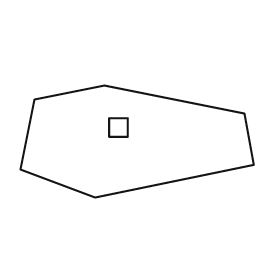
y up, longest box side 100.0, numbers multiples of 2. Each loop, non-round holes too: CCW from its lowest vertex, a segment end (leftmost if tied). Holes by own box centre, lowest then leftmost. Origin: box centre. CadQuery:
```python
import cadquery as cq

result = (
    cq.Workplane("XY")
    .moveTo(-18.0, -24.0)
    .lineTo(50.0, -10.0)
    .lineTo(46.0, 12.0)
    .lineTo(-14.0, 24.0)
    .lineTo(-44.0, 18.0)
    .lineTo(-50.0, -12.0)
    .close()
    .moveTo(-12.0, 2.0)
    .lineTo(-4.0, 2.0)
    .lineTo(-4.0, 10.0)
    .lineTo(-12.0, 10.0)
    .close()
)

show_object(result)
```